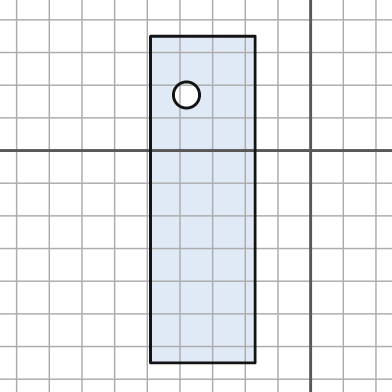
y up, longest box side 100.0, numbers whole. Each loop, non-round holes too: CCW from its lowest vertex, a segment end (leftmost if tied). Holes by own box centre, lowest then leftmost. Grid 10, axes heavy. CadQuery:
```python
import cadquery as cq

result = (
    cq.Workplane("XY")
    .moveTo(-49.0, -65.0)
    .lineTo(-17.0, -65.0)
    .lineTo(-17.0, 35.0)
    .lineTo(-49.0, 35.0)
    .close()
    .moveTo(-38.0, 17.0)
    .circle(4.0)
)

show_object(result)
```